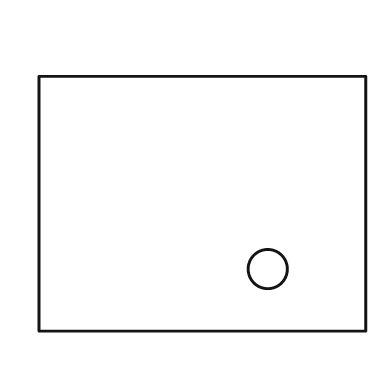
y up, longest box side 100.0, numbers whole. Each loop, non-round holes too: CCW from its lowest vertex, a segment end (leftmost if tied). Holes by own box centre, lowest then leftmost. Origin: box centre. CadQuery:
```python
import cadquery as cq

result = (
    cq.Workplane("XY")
    .moveTo(-50.0, -39.0)
    .lineTo(50.0, -39.0)
    .lineTo(50.0, 39.0)
    .lineTo(-50.0, 39.0)
    .close()
    .moveTo(20.0, -20.0)
    .circle(6.0)
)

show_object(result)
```